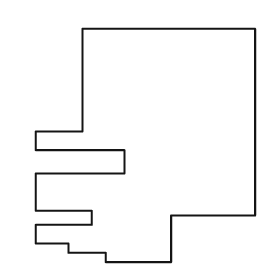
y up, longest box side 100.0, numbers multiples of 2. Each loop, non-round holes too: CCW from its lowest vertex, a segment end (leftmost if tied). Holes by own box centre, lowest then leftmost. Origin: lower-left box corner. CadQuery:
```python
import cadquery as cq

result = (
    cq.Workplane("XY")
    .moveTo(30.0, 0.0)
    .lineTo(58.0, 0.0)
    .lineTo(58.0, 20.0)
    .lineTo(94.0, 20.0)
    .lineTo(94.0, 100.0)
    .lineTo(20.0, 100.0)
    .lineTo(20.0, 56.0)
    .lineTo(0.0, 56.0)
    .lineTo(0.0, 48.0)
    .lineTo(38.0, 48.0)
    .lineTo(38.0, 38.0)
    .lineTo(0.0, 38.0)
    .lineTo(0.0, 22.0)
    .lineTo(24.0, 22.0)
    .lineTo(24.0, 16.0)
    .lineTo(0.0, 16.0)
    .lineTo(0.0, 8.0)
    .lineTo(14.0, 8.0)
    .lineTo(14.0, 4.0)
    .lineTo(30.0, 4.0)
    .close()
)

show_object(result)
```